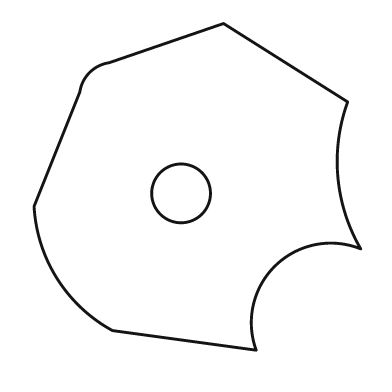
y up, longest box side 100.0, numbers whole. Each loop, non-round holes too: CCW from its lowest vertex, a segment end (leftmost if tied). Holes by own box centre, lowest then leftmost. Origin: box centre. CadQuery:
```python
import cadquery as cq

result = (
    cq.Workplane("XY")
    .moveTo(18.0, -50.0)
    .threePointArc((24.0, -24.0), (50.0, -19.0))
    .threePointArc((43.0, 3.0), (46.0, 26.0))
    .lineTo(8.0, 50.0)
    .lineTo(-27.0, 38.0)
    .threePointArc((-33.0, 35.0), (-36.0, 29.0))
    .lineTo(-50.0, -6.0)
    .threePointArc((-43.0, -28.0), (-26.0, -44.0))
    .close()
    .moveTo(-5.0, -2.0)
    .circle(9.0)
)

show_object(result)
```